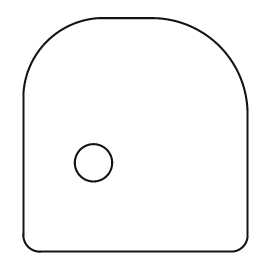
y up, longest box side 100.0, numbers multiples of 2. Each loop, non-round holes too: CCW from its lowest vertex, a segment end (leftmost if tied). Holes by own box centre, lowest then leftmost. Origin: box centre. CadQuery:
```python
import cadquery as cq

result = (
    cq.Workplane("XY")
    .moveTo(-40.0, -50.0)
    .lineTo(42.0, -50.0)
    .threePointArc((46.0, -48.0), (48.0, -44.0))
    .lineTo(48.0, 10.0)
    .threePointArc((36.0, 38.0), (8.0, 50.0))
    .lineTo(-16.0, 50.0)
    .threePointArc((-38.0, 40.0), (-48.0, 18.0))
    .lineTo(-48.0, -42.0)
    .threePointArc((-46.0, -48.0), (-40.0, -50.0))
    .close()
    .moveTo(-18.0, -12.0)
    .circle(8.0)
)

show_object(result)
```